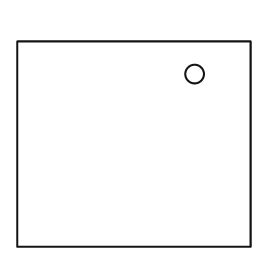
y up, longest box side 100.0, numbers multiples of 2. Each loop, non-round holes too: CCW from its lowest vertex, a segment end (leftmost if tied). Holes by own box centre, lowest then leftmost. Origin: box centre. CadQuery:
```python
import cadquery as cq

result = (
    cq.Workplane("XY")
    .moveTo(-50.0, -44.0)
    .lineTo(50.0, -44.0)
    .lineTo(50.0, 44.0)
    .lineTo(-50.0, 44.0)
    .close()
    .moveTo(26.0, 30.0)
    .circle(4.0)
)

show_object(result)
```